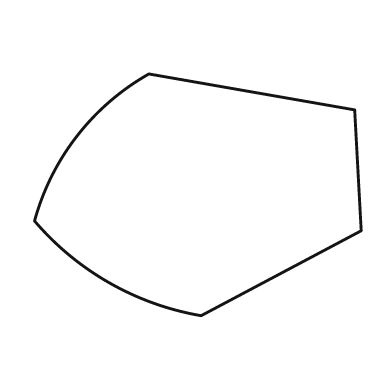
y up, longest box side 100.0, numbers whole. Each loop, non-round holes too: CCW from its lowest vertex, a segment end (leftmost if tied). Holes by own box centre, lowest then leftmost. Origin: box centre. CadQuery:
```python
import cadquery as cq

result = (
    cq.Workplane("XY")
    .moveTo(1.0, -37.0)
    .lineTo(50.0, -11.0)
    .lineTo(48.0, 26.0)
    .lineTo(-15.0, 37.0)
    .threePointArc((-37.0, 18.0), (-50.0, -8.0))
    .threePointArc((-27.0, -27.0), (1.0, -37.0))
    .close()
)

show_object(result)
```